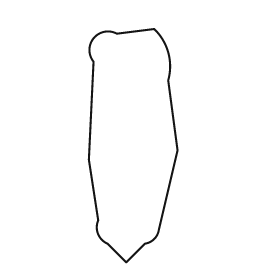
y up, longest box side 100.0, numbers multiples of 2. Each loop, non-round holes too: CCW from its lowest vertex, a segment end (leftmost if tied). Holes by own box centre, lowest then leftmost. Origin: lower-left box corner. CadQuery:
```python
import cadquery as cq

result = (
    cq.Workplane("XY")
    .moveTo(16.0, 0.0)
    .lineTo(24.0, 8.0)
    .threePointArc((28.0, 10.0), (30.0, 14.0))
    .lineTo(38.0, 48.0)
    .lineTo(34.0, 78.0)
    .threePointArc((34.0, 90.0), (28.0, 100.0))
    .lineTo(12.0, 98.0)
    .threePointArc((2.0, 96.0), (2.0, 86.0))
    .lineTo(0.0, 44.0)
    .lineTo(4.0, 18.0)
    .threePointArc((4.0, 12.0), (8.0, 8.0))
    .close()
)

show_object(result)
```